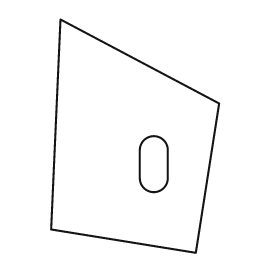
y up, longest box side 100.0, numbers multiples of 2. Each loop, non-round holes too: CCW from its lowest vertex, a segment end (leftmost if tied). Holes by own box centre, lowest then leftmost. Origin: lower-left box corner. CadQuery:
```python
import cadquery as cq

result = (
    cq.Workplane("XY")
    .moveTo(62.0, 0.0)
    .lineTo(72.0, 64.0)
    .lineTo(4.0, 100.0)
    .lineTo(0.0, 10.0)
    .close()
    .moveTo(38.0, 32.0)
    .threePointArc((44.0, 26.0), (50.0, 32.0))
    .lineTo(50.0, 44.0)
    .threePointArc((44.0, 50.0), (38.0, 44.0))
    .close()
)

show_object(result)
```